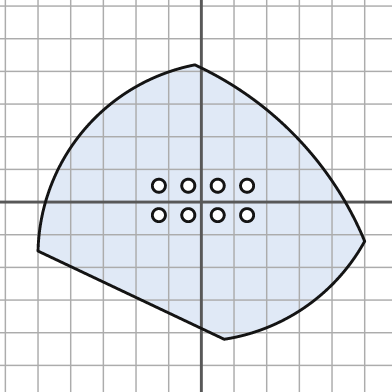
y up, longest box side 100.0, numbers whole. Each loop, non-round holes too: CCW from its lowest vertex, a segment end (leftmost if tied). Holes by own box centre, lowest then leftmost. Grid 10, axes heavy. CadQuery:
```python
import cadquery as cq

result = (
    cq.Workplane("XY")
    .moveTo(7.0, -42.0)
    .threePointArc((32.0, -32.0), (50.0, -12.0))
    .threePointArc((29.0, 20.0), (-2.0, 42.0))
    .threePointArc((-36.0, 22.0), (-50.0, -15.0))
    .close()
    .moveTo(-13.0, -4.0)
    .circle(2.0)
    .moveTo(-4.0, -4.0)
    .circle(2.0)
    .moveTo(5.0, -4.0)
    .circle(2.0)
    .moveTo(14.0, -4.0)
    .circle(2.0)
    .moveTo(-13.0, 5.0)
    .circle(2.0)
    .moveTo(-4.0, 5.0)
    .circle(2.0)
    .moveTo(5.0, 5.0)
    .circle(2.0)
    .moveTo(14.0, 5.0)
    .circle(2.0)
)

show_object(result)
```